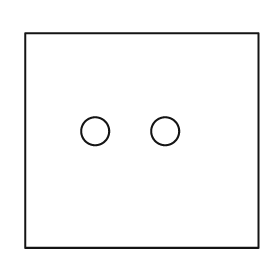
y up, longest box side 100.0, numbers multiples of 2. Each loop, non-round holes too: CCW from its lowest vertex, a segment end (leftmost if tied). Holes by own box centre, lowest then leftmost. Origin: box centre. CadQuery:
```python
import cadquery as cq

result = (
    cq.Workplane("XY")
    .moveTo(-50.0, -46.0)
    .lineTo(50.0, -46.0)
    .lineTo(50.0, 46.0)
    .lineTo(-50.0, 46.0)
    .close()
    .moveTo(-20.0, 4.0)
    .circle(6.0)
    .moveTo(10.0, 4.0)
    .circle(6.0)
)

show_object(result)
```